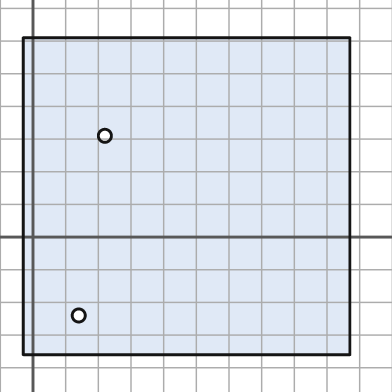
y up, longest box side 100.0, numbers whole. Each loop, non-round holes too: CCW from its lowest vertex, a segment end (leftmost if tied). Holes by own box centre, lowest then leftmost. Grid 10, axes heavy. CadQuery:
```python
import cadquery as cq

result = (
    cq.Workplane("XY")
    .moveTo(-3.0, -36.0)
    .lineTo(97.0, -36.0)
    .lineTo(97.0, 61.0)
    .lineTo(-3.0, 61.0)
    .close()
    .moveTo(14.0, -24.0)
    .circle(2.0)
    .moveTo(22.0, 31.0)
    .circle(2.0)
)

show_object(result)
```